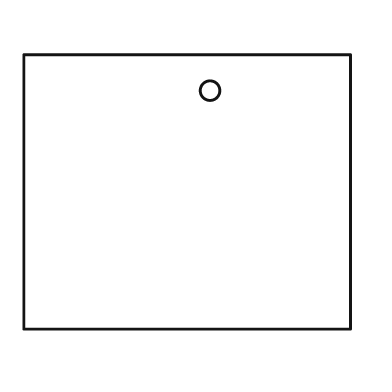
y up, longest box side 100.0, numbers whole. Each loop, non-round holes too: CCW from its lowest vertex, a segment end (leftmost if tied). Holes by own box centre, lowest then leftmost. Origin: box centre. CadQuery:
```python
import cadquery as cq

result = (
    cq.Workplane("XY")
    .moveTo(-50.0, -42.0)
    .lineTo(50.0, -42.0)
    .lineTo(50.0, 42.0)
    .lineTo(-50.0, 42.0)
    .close()
    .moveTo(7.0, 31.0)
    .circle(3.0)
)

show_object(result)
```